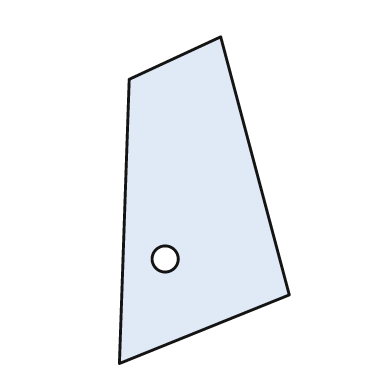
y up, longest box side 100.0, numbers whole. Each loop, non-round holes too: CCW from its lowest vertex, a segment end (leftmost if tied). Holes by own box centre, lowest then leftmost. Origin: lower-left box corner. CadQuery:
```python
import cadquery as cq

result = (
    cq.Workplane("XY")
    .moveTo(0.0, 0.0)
    .lineTo(52.0, 21.0)
    .lineTo(31.0, 100.0)
    .lineTo(3.0, 87.0)
    .close()
    .moveTo(14.0, 32.0)
    .circle(4.0)
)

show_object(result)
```